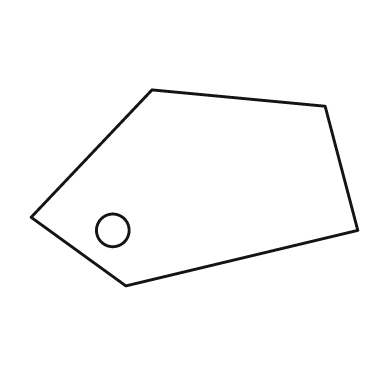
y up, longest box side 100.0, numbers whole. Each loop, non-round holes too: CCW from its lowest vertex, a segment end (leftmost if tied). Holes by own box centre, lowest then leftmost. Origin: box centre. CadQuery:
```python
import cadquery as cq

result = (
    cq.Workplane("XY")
    .moveTo(-21.0, -30.0)
    .lineTo(50.0, -13.0)
    .lineTo(40.0, 25.0)
    .lineTo(-13.0, 30.0)
    .lineTo(-50.0, -9.0)
    .close()
    .moveTo(-25.0, -13.0)
    .circle(5.0)
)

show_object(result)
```